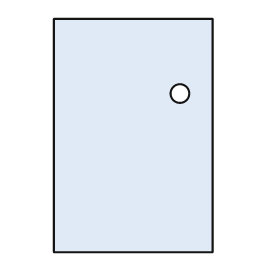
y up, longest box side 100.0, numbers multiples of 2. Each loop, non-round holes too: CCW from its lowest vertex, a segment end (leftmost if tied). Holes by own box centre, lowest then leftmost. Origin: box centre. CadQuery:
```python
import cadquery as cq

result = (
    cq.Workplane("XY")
    .moveTo(-34.0, -50.0)
    .lineTo(34.0, -50.0)
    .lineTo(34.0, 50.0)
    .lineTo(-34.0, 50.0)
    .close()
    .moveTo(20.0, 18.0)
    .circle(4.0)
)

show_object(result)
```